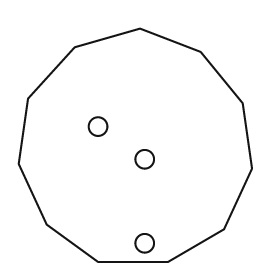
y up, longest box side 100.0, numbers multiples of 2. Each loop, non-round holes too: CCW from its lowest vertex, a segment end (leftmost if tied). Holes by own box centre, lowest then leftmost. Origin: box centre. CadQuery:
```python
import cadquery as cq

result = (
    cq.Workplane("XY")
    .moveTo(-16.0, -50.0)
    .lineTo(14.0, -50.0)
    .lineTo(38.0, -36.0)
    .lineTo(50.0, -10.0)
    .lineTo(46.0, 18.0)
    .lineTo(28.0, 40.0)
    .lineTo(2.0, 50.0)
    .lineTo(-26.0, 42.0)
    .lineTo(-46.0, 20.0)
    .lineTo(-50.0, -8.0)
    .lineTo(-38.0, -34.0)
    .close()
    .moveTo(4.0, -42.0)
    .circle(4.0)
    .moveTo(4.0, -6.0)
    .circle(4.0)
    .moveTo(-16.0, 8.0)
    .circle(4.0)
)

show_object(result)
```